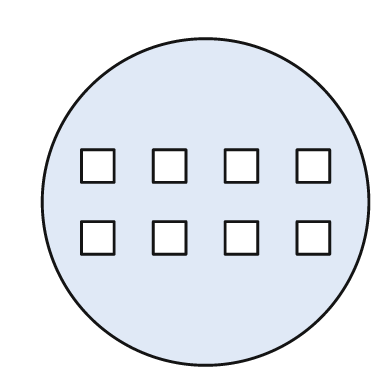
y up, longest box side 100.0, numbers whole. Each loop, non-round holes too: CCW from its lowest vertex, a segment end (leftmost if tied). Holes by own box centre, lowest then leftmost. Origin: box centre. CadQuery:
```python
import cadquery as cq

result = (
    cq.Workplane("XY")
    .moveTo(0.0, 0.0)
    .circle(50.0)
    .moveTo(-38.0, -16.0)
    .lineTo(-28.0, -16.0)
    .lineTo(-28.0, -6.0)
    .lineTo(-38.0, -6.0)
    .close()
    .moveTo(-16.0, -16.0)
    .lineTo(-6.0, -16.0)
    .lineTo(-6.0, -6.0)
    .lineTo(-16.0, -6.0)
    .close()
    .moveTo(6.0, -16.0)
    .lineTo(16.0, -16.0)
    .lineTo(16.0, -6.0)
    .lineTo(6.0, -6.0)
    .close()
    .moveTo(28.0, -16.0)
    .lineTo(38.0, -16.0)
    .lineTo(38.0, -6.0)
    .lineTo(28.0, -6.0)
    .close()
    .moveTo(-38.0, 6.0)
    .lineTo(-28.0, 6.0)
    .lineTo(-28.0, 16.0)
    .lineTo(-38.0, 16.0)
    .close()
    .moveTo(-16.0, 6.0)
    .lineTo(-6.0, 6.0)
    .lineTo(-6.0, 16.0)
    .lineTo(-16.0, 16.0)
    .close()
    .moveTo(6.0, 6.0)
    .lineTo(16.0, 6.0)
    .lineTo(16.0, 16.0)
    .lineTo(6.0, 16.0)
    .close()
    .moveTo(28.0, 6.0)
    .lineTo(38.0, 6.0)
    .lineTo(38.0, 16.0)
    .lineTo(28.0, 16.0)
    .close()
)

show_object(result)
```